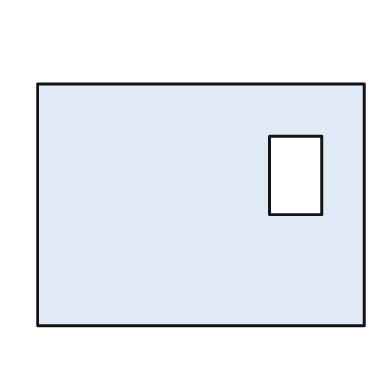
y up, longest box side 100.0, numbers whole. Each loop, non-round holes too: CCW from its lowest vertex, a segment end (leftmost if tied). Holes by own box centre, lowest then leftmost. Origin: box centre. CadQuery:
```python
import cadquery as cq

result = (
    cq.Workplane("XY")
    .moveTo(-50.0, -37.0)
    .lineTo(50.0, -37.0)
    .lineTo(50.0, 37.0)
    .lineTo(-50.0, 37.0)
    .close()
    .moveTo(21.0, -3.0)
    .lineTo(37.0, -3.0)
    .lineTo(37.0, 21.0)
    .lineTo(21.0, 21.0)
    .close()
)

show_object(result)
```